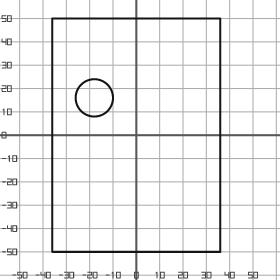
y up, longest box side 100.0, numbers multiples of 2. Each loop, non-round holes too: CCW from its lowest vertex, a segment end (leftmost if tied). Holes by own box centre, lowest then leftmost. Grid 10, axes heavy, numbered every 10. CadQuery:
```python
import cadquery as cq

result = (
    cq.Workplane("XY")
    .moveTo(-36.0, -50.0)
    .lineTo(36.0, -50.0)
    .lineTo(36.0, 50.0)
    .lineTo(-36.0, 50.0)
    .close()
    .moveTo(-18.0, 16.0)
    .circle(8.0)
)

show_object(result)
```